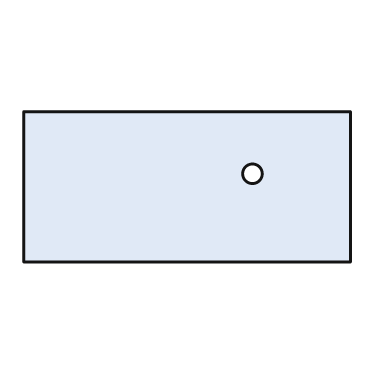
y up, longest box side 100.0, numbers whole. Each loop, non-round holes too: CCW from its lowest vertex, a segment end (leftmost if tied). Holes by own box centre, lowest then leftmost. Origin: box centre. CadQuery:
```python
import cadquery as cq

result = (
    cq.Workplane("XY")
    .moveTo(-50.0, -23.0)
    .lineTo(50.0, -23.0)
    .lineTo(50.0, 23.0)
    .lineTo(-50.0, 23.0)
    .close()
    .moveTo(20.0, 4.0)
    .circle(3.0)
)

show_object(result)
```